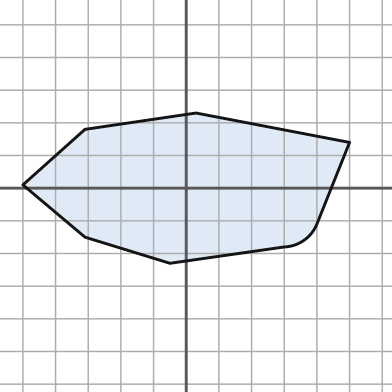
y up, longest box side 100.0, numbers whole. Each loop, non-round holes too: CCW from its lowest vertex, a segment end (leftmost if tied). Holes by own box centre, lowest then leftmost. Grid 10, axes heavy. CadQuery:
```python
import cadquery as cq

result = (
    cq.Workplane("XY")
    .moveTo(-5.0, -23.0)
    .lineTo(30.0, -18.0)
    .threePointArc((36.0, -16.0), (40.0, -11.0))
    .lineTo(50.0, 14.0)
    .lineTo(3.0, 23.0)
    .lineTo(-31.0, 18.0)
    .lineTo(-50.0, 1.0)
    .lineTo(-31.0, -15.0)
    .close()
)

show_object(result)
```